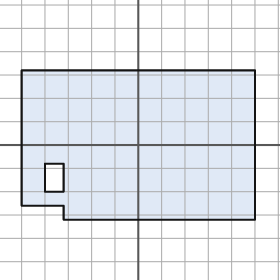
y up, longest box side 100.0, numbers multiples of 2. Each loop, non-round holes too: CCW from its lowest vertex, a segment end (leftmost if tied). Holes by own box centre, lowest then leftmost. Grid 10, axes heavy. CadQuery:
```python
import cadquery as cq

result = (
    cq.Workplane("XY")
    .moveTo(-32.0, -32.0)
    .lineTo(50.0, -32.0)
    .lineTo(50.0, 32.0)
    .lineTo(-50.0, 32.0)
    .lineTo(-50.0, -26.0)
    .lineTo(-32.0, -26.0)
    .close()
    .moveTo(-40.0, -20.0)
    .lineTo(-32.0, -20.0)
    .lineTo(-32.0, -8.0)
    .lineTo(-40.0, -8.0)
    .close()
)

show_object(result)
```